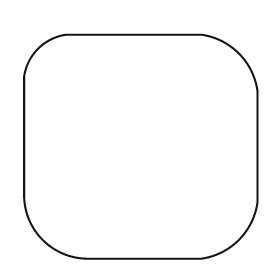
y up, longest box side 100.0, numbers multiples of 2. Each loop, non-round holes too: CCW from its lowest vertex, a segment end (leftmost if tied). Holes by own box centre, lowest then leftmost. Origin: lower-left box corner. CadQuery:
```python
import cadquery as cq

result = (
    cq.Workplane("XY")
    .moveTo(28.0, 0.0)
    .lineTo(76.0, 0.0)
    .threePointArc((92.0, 8.0), (100.0, 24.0))
    .lineTo(100.0, 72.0)
    .threePointArc((92.0, 88.0), (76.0, 96.0))
    .lineTo(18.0, 96.0)
    .threePointArc((6.0, 90.0), (0.0, 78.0))
    .lineTo(0.0, 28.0)
    .threePointArc((8.0, 8.0), (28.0, 0.0))
    .close()
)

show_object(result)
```